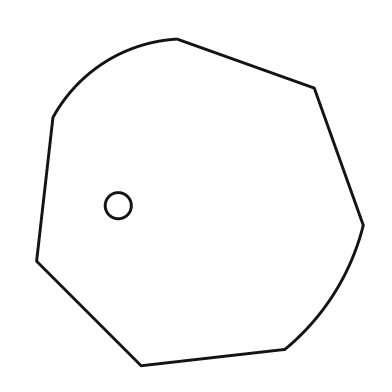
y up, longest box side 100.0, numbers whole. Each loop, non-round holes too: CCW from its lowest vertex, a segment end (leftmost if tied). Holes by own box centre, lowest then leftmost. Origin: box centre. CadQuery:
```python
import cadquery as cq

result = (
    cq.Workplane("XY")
    .moveTo(-18.0, -50.0)
    .lineTo(26.0, -45.0)
    .threePointArc((41.0, -28.0), (50.0, -7.0))
    .lineTo(35.0, 35.0)
    .lineTo(-7.0, 50.0)
    .threePointArc((-29.0, 43.0), (-45.0, 26.0))
    .lineTo(-50.0, -18.0)
    .close()
    .moveTo(-25.0, -1.0)
    .circle(4.0)
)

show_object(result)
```